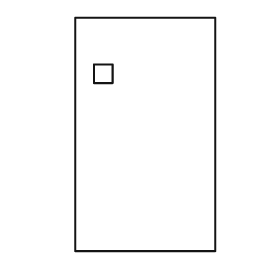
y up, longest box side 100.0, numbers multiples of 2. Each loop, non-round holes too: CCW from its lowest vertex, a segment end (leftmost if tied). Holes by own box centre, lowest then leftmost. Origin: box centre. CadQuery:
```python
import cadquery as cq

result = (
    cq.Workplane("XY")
    .moveTo(-30.0, -50.0)
    .lineTo(30.0, -50.0)
    .lineTo(30.0, 50.0)
    .lineTo(-30.0, 50.0)
    .close()
    .moveTo(-22.0, 22.0)
    .lineTo(-14.0, 22.0)
    .lineTo(-14.0, 30.0)
    .lineTo(-22.0, 30.0)
    .close()
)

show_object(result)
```